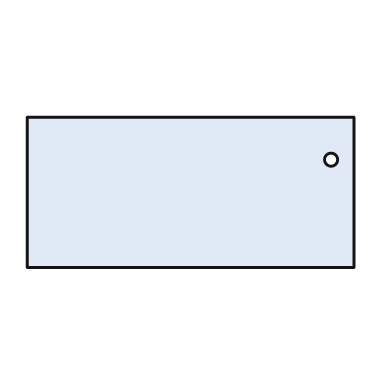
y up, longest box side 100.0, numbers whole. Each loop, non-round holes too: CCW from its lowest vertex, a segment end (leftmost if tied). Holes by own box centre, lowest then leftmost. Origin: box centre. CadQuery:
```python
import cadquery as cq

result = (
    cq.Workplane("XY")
    .moveTo(-50.0, -23.0)
    .lineTo(50.0, -23.0)
    .lineTo(50.0, 23.0)
    .lineTo(-50.0, 23.0)
    .close()
    .moveTo(43.0, 10.0)
    .circle(2.0)
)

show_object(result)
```